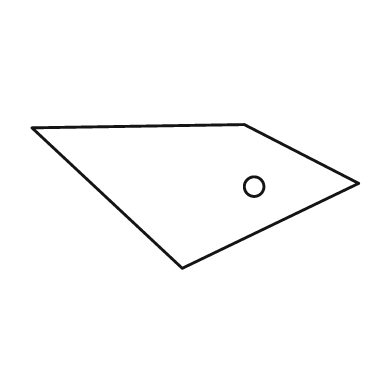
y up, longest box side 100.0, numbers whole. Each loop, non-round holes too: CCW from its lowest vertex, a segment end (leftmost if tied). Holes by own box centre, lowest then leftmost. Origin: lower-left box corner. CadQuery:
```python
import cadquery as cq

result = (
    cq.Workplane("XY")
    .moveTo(46.0, 0.0)
    .lineTo(100.0, 26.0)
    .lineTo(65.0, 44.0)
    .lineTo(0.0, 43.0)
    .close()
    .moveTo(68.0, 25.0)
    .circle(3.0)
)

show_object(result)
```